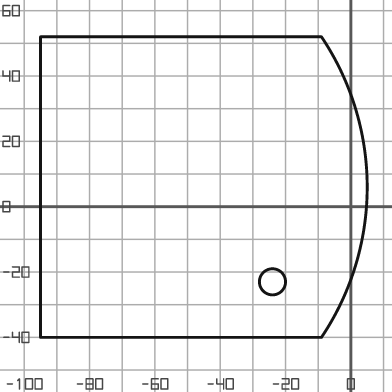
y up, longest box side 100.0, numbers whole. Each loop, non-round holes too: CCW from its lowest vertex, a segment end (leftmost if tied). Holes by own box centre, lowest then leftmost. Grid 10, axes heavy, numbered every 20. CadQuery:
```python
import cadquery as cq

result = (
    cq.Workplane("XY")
    .moveTo(-95.0, -40.0)
    .lineTo(-9.0, -40.0)
    .threePointArc((5.0, 6.0), (-9.0, 52.0))
    .lineTo(-95.0, 52.0)
    .close()
    .moveTo(-24.0, -23.0)
    .circle(4.0)
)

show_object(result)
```